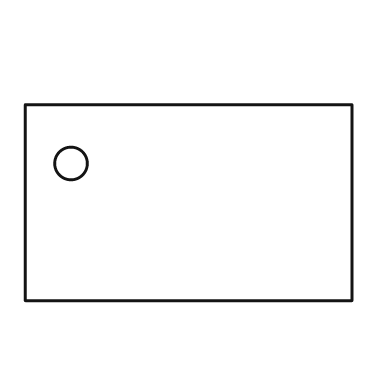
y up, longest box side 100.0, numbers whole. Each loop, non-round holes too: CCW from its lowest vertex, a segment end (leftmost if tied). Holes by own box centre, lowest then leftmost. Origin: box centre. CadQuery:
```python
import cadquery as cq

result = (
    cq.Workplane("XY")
    .moveTo(-50.0, -30.0)
    .lineTo(50.0, -30.0)
    .lineTo(50.0, 30.0)
    .lineTo(-50.0, 30.0)
    .close()
    .moveTo(-36.0, 12.0)
    .circle(5.0)
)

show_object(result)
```